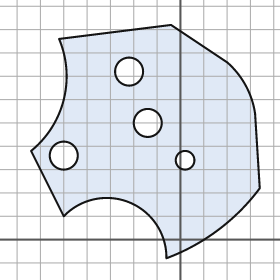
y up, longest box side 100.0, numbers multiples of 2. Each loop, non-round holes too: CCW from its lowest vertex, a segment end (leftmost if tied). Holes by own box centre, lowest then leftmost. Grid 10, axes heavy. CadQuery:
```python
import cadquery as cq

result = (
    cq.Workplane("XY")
    .moveTo(-6.0, -8.0)
    .threePointArc((16.0, 4.0), (34.0, 22.0))
    .lineTo(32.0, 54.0)
    .threePointArc((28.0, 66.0), (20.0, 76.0))
    .lineTo(-4.0, 92.0)
    .lineTo(-52.0, 86.0)
    .threePointArc((-50.0, 60.0), (-64.0, 38.0))
    .lineTo(-50.0, 10.0)
    .threePointArc((-22.0, 16.0), (-6.0, -8.0))
    .close()
    .moveTo(2.0, 34.0)
    .circle(4.0)
    .moveTo(-50.0, 36.0)
    .circle(6.0)
    .moveTo(-14.0, 50.0)
    .circle(6.0)
    .moveTo(-22.0, 72.0)
    .circle(6.0)
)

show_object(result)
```